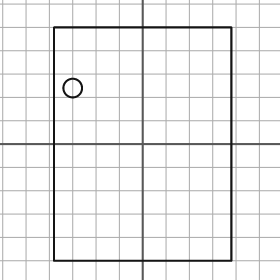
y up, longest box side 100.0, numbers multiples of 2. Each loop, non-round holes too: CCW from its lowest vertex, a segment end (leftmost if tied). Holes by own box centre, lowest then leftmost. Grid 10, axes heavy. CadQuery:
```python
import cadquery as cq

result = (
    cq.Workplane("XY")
    .moveTo(-38.0, -50.0)
    .lineTo(38.0, -50.0)
    .lineTo(38.0, 50.0)
    .lineTo(-38.0, 50.0)
    .close()
    .moveTo(-30.0, 24.0)
    .circle(4.0)
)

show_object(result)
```